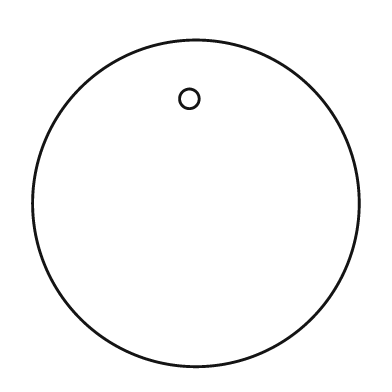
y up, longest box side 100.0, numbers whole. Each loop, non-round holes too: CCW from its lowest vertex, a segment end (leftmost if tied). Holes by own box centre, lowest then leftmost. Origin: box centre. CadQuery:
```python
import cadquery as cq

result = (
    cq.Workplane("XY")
    .moveTo(0.0, 0.0)
    .circle(50.0)
    .moveTo(-2.0, 32.0)
    .circle(3.0)
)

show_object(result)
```